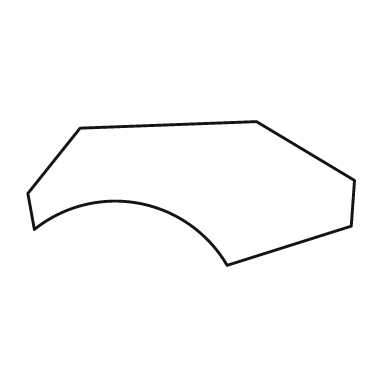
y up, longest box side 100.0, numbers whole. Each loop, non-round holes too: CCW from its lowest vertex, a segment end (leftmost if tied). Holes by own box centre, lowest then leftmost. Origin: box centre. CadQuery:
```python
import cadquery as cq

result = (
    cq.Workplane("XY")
    .moveTo(11.0, -22.0)
    .lineTo(49.0, -10.0)
    .lineTo(50.0, 4.0)
    .lineTo(20.0, 22.0)
    .lineTo(-34.0, 20.0)
    .lineTo(-50.0, 0.0)
    .lineTo(-48.0, -11.0)
    .threePointArc((-16.0, -3.0), (11.0, -22.0))
    .close()
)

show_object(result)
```